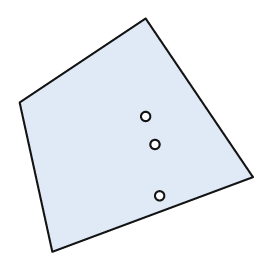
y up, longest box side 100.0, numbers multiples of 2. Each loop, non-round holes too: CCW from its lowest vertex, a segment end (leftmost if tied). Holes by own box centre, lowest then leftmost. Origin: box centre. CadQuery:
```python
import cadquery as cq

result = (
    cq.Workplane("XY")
    .moveTo(-36.0, -50.0)
    .lineTo(50.0, -18.0)
    .lineTo(4.0, 50.0)
    .lineTo(-50.0, 14.0)
    .close()
    .moveTo(10.0, -26.0)
    .circle(2.0)
    .moveTo(8.0, -4.0)
    .circle(2.0)
    .moveTo(4.0, 8.0)
    .circle(2.0)
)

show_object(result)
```